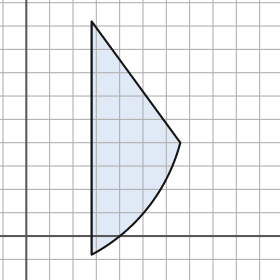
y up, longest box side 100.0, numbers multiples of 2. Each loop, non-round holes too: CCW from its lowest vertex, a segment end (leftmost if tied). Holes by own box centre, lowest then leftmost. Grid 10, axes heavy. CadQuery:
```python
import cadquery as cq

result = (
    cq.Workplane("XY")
    .moveTo(28.0, -8.0)
    .threePointArc((52.0, 12.0), (66.0, 40.0))
    .lineTo(28.0, 92.0)
    .close()
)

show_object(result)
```